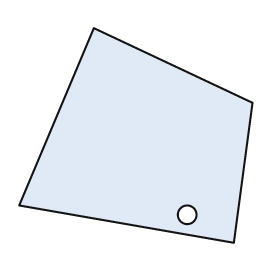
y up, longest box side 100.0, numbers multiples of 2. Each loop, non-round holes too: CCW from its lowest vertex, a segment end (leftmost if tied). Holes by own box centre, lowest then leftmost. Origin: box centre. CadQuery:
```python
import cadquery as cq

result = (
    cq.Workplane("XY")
    .moveTo(42.0, -46.0)
    .lineTo(50.0, 14.0)
    .lineTo(-18.0, 46.0)
    .lineTo(-50.0, -30.0)
    .close()
    .moveTo(22.0, -34.0)
    .circle(4.0)
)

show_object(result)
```